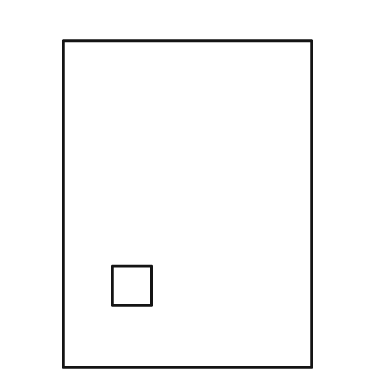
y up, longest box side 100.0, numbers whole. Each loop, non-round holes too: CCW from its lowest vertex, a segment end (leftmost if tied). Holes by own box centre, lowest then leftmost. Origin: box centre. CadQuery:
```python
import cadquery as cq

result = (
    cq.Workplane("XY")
    .moveTo(-38.0, -50.0)
    .lineTo(38.0, -50.0)
    .lineTo(38.0, 50.0)
    .lineTo(-38.0, 50.0)
    .close()
    .moveTo(-23.0, -31.0)
    .lineTo(-11.0, -31.0)
    .lineTo(-11.0, -19.0)
    .lineTo(-23.0, -19.0)
    .close()
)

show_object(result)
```